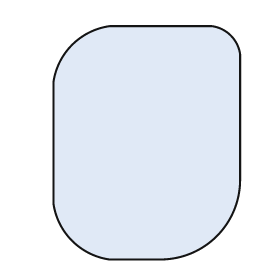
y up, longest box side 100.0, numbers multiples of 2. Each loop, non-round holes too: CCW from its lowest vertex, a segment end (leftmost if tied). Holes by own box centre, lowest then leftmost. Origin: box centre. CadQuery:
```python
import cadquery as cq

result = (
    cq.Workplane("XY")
    .moveTo(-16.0, -50.0)
    .lineTo(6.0, -50.0)
    .threePointArc((30.0, -40.0), (40.0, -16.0))
    .lineTo(40.0, 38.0)
    .threePointArc((36.0, 46.0), (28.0, 50.0))
    .lineTo(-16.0, 50.0)
    .threePointArc((-32.0, 42.0), (-40.0, 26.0))
    .lineTo(-40.0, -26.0)
    .threePointArc((-32.0, -42.0), (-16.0, -50.0))
    .close()
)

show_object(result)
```